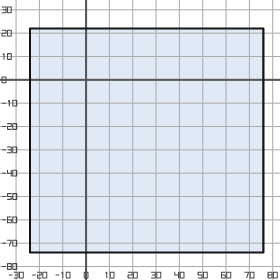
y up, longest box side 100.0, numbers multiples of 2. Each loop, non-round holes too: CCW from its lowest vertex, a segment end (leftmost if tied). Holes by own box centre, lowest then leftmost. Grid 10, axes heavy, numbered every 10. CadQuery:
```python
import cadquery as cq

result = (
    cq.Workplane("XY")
    .moveTo(-24.0, -74.0)
    .lineTo(76.0, -74.0)
    .lineTo(76.0, 22.0)
    .lineTo(-24.0, 22.0)
    .close()
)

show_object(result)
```